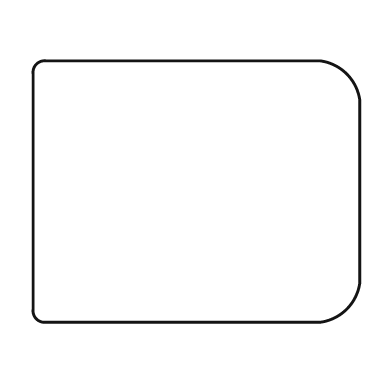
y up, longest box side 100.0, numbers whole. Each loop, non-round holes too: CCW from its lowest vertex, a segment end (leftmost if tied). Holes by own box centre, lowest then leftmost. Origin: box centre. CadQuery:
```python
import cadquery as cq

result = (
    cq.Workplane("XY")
    .moveTo(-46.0, -40.0)
    .lineTo(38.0, -40.0)
    .threePointArc((46.0, -36.0), (50.0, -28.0))
    .lineTo(50.0, 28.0)
    .threePointArc((46.0, 36.0), (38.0, 40.0))
    .lineTo(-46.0, 40.0)
    .threePointArc((-49.0, 39.0), (-50.0, 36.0))
    .lineTo(-50.0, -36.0)
    .threePointArc((-49.0, -39.0), (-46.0, -40.0))
    .close()
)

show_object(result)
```